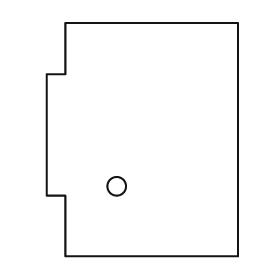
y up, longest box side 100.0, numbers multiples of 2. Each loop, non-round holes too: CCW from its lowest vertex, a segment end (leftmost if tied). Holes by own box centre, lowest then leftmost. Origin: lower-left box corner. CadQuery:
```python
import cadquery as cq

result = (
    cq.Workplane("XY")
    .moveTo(8.0, 0.0)
    .lineTo(82.0, 0.0)
    .lineTo(82.0, 100.0)
    .lineTo(8.0, 100.0)
    .lineTo(8.0, 78.0)
    .lineTo(0.0, 78.0)
    .lineTo(0.0, 26.0)
    .lineTo(8.0, 26.0)
    .close()
    .moveTo(30.0, 30.0)
    .circle(4.0)
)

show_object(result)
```